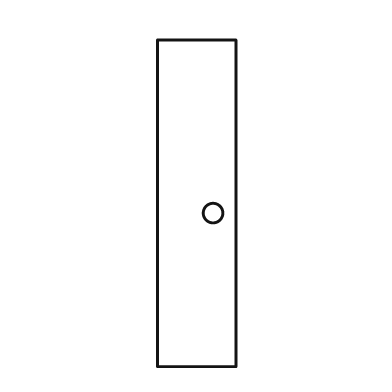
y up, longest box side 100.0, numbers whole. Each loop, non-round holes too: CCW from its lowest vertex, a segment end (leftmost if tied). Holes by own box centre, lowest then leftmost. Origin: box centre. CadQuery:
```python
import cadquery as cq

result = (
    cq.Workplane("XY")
    .moveTo(-12.0, -50.0)
    .lineTo(12.0, -50.0)
    .lineTo(12.0, 50.0)
    .lineTo(-12.0, 50.0)
    .close()
    .moveTo(5.0, -3.0)
    .circle(3.0)
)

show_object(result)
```